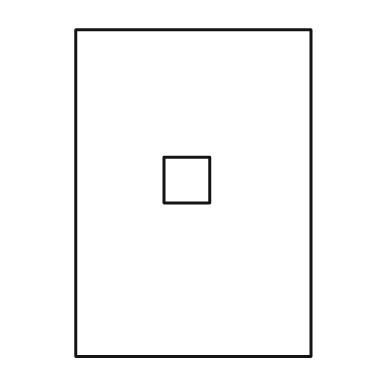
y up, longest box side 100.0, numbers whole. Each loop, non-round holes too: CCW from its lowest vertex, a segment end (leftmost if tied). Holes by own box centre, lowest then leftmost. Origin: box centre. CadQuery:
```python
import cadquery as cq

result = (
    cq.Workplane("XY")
    .moveTo(-36.0, -50.0)
    .lineTo(36.0, -50.0)
    .lineTo(36.0, 50.0)
    .lineTo(-36.0, 50.0)
    .close()
    .moveTo(-9.0, -3.0)
    .lineTo(5.0, -3.0)
    .lineTo(5.0, 11.0)
    .lineTo(-9.0, 11.0)
    .close()
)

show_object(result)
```